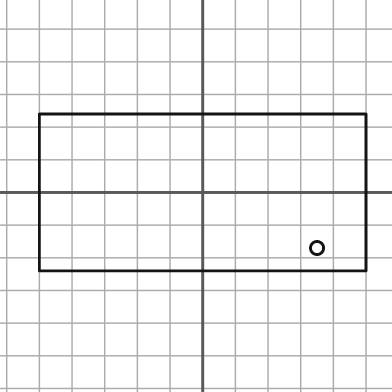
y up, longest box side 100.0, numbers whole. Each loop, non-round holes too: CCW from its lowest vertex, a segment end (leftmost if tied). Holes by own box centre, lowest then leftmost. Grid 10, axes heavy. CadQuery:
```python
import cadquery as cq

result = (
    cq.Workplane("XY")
    .moveTo(-50.0, -24.0)
    .lineTo(50.0, -24.0)
    .lineTo(50.0, 24.0)
    .lineTo(-50.0, 24.0)
    .close()
    .moveTo(35.0, -17.0)
    .circle(2.0)
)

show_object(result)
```